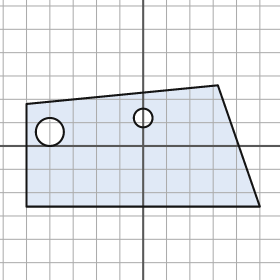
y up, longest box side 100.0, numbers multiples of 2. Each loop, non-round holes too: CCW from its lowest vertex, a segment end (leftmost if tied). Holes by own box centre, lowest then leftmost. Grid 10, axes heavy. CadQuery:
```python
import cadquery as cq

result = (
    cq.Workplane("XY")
    .moveTo(-50.0, -26.0)
    .lineTo(50.0, -26.0)
    .lineTo(32.0, 26.0)
    .lineTo(-50.0, 18.0)
    .close()
    .moveTo(-40.0, 6.0)
    .circle(6.0)
    .moveTo(0.0, 12.0)
    .circle(4.0)
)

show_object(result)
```